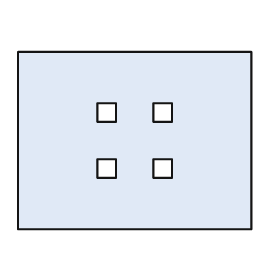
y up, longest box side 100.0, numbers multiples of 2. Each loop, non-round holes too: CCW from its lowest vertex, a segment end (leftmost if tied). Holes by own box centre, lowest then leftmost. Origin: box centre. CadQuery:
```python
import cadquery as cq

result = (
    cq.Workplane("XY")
    .moveTo(-50.0, -38.0)
    .lineTo(50.0, -38.0)
    .lineTo(50.0, 38.0)
    .lineTo(-50.0, 38.0)
    .close()
    .moveTo(-16.0, -16.0)
    .lineTo(-8.0, -16.0)
    .lineTo(-8.0, -8.0)
    .lineTo(-16.0, -8.0)
    .close()
    .moveTo(8.0, -16.0)
    .lineTo(16.0, -16.0)
    .lineTo(16.0, -8.0)
    .lineTo(8.0, -8.0)
    .close()
    .moveTo(-16.0, 8.0)
    .lineTo(-8.0, 8.0)
    .lineTo(-8.0, 16.0)
    .lineTo(-16.0, 16.0)
    .close()
    .moveTo(8.0, 8.0)
    .lineTo(16.0, 8.0)
    .lineTo(16.0, 16.0)
    .lineTo(8.0, 16.0)
    .close()
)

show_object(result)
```